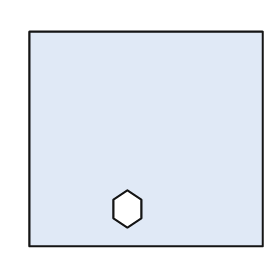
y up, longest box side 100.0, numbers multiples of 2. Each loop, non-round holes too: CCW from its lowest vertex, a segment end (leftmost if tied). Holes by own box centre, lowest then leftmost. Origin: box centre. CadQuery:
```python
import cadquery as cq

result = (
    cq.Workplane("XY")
    .moveTo(-50.0, -46.0)
    .lineTo(50.0, -46.0)
    .lineTo(50.0, 46.0)
    .lineTo(-50.0, 46.0)
    .close()
    .moveTo(-8.0, -38.0)
    .lineTo(-2.0, -34.0)
    .lineTo(-2.0, -26.0)
    .lineTo(-8.0, -22.0)
    .lineTo(-14.0, -26.0)
    .lineTo(-14.0, -34.0)
    .close()
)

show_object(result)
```